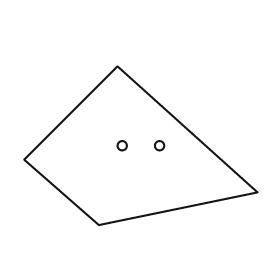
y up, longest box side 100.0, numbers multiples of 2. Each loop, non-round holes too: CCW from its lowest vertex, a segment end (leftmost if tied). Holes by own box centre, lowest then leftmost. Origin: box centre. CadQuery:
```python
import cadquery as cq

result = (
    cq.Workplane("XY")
    .moveTo(-18.0, -34.0)
    .lineTo(50.0, -20.0)
    .lineTo(-10.0, 34.0)
    .lineTo(-50.0, -6.0)
    .close()
    .moveTo(-8.0, 0.0)
    .circle(2.0)
    .moveTo(8.0, 0.0)
    .circle(2.0)
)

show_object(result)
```